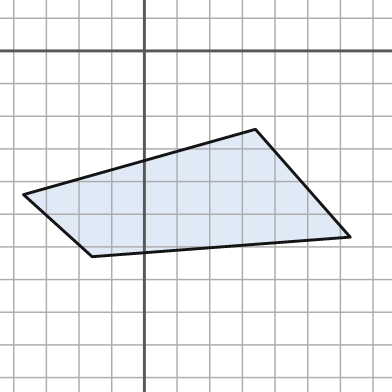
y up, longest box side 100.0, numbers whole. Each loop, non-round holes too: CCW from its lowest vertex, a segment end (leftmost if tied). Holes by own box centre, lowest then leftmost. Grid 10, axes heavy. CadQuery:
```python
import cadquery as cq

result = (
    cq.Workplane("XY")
    .moveTo(-16.0, -63.0)
    .lineTo(63.0, -57.0)
    .lineTo(34.0, -24.0)
    .lineTo(-37.0, -44.0)
    .close()
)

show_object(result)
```